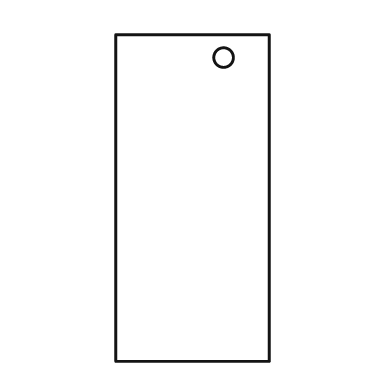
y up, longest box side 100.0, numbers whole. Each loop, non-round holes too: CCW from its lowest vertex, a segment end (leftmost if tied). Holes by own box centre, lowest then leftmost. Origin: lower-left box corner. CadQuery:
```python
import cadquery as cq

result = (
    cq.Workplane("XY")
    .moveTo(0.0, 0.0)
    .lineTo(47.0, 0.0)
    .lineTo(47.0, 100.0)
    .lineTo(0.0, 100.0)
    .close()
    .moveTo(33.0, 93.0)
    .circle(3.0)
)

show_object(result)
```